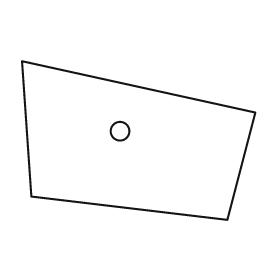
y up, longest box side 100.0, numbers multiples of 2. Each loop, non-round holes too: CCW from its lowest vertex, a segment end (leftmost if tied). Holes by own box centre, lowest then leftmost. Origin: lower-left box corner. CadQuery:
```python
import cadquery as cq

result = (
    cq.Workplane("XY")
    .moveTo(88.0, 0.0)
    .lineTo(100.0, 46.0)
    .lineTo(0.0, 68.0)
    .lineTo(4.0, 10.0)
    .close()
    .moveTo(42.0, 38.0)
    .circle(4.0)
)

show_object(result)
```